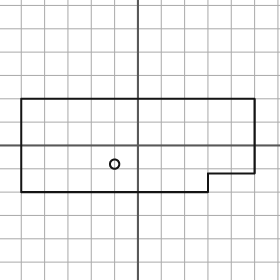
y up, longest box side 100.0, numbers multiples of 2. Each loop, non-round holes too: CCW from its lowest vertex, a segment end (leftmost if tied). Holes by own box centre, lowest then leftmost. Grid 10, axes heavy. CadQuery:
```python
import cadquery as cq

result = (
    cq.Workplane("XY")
    .moveTo(-50.0, -20.0)
    .lineTo(30.0, -20.0)
    .lineTo(30.0, -12.0)
    .lineTo(50.0, -12.0)
    .lineTo(50.0, 20.0)
    .lineTo(-50.0, 20.0)
    .close()
    .moveTo(-10.0, -8.0)
    .circle(2.0)
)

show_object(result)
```